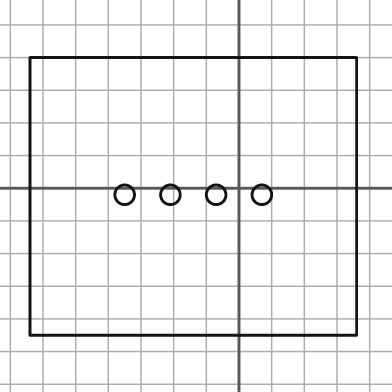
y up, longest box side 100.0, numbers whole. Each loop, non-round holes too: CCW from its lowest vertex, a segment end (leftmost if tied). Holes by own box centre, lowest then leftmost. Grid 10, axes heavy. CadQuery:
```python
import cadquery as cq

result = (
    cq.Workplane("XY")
    .moveTo(-64.0, -45.0)
    .lineTo(36.0, -45.0)
    .lineTo(36.0, 40.0)
    .lineTo(-64.0, 40.0)
    .close()
    .moveTo(-35.0, -2.0)
    .circle(3.0)
    .moveTo(-21.0, -2.0)
    .circle(3.0)
    .moveTo(-7.0, -2.0)
    .circle(3.0)
    .moveTo(7.0, -2.0)
    .circle(3.0)
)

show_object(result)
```